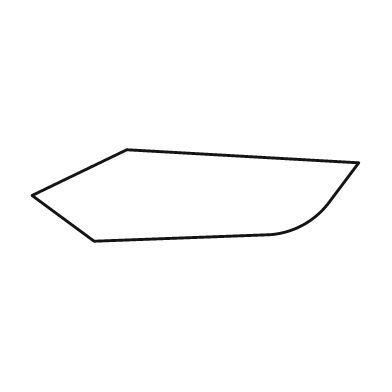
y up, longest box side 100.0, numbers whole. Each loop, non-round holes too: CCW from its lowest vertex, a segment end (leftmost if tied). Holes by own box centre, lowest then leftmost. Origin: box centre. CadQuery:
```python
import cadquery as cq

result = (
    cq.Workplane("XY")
    .moveTo(-31.0, -14.0)
    .lineTo(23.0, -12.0)
    .threePointArc((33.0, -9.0), (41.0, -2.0))
    .lineTo(50.0, 10.0)
    .lineTo(-21.0, 14.0)
    .lineTo(-50.0, 0.0)
    .close()
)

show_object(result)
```